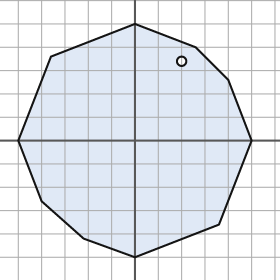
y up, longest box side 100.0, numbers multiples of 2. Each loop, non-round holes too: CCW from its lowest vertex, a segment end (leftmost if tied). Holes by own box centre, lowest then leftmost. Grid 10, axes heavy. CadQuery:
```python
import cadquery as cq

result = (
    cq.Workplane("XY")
    .moveTo(0.0, -50.0)
    .lineTo(36.0, -36.0)
    .lineTo(50.0, 0.0)
    .lineTo(40.0, 26.0)
    .lineTo(26.0, 40.0)
    .lineTo(0.0, 50.0)
    .lineTo(-36.0, 36.0)
    .lineTo(-50.0, 0.0)
    .lineTo(-40.0, -26.0)
    .lineTo(-22.0, -42.0)
    .close()
    .moveTo(20.0, 34.0)
    .circle(2.0)
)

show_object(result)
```